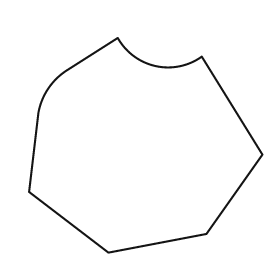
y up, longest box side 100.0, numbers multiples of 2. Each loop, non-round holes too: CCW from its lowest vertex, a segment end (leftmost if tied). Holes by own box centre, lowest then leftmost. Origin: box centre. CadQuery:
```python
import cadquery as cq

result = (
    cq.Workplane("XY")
    .moveTo(-16.0, -46.0)
    .lineTo(26.0, -38.0)
    .lineTo(50.0, -4.0)
    .lineTo(24.0, 38.0)
    .threePointArc((4.0, 34.0), (-12.0, 46.0))
    .lineTo(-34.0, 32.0)
    .threePointArc((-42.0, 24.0), (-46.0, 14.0))
    .lineTo(-50.0, -20.0)
    .close()
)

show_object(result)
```